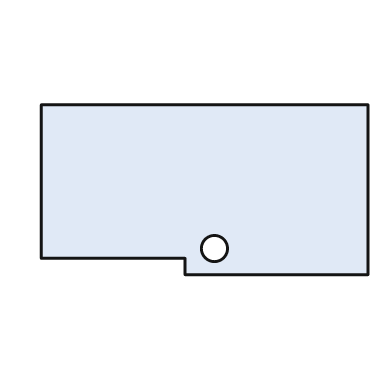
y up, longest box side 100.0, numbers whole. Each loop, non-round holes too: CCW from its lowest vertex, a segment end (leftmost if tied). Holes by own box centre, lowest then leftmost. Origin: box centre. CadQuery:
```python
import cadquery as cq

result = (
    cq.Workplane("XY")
    .moveTo(-6.0, -26.0)
    .lineTo(50.0, -26.0)
    .lineTo(50.0, 26.0)
    .lineTo(-50.0, 26.0)
    .lineTo(-50.0, -21.0)
    .lineTo(-6.0, -21.0)
    .close()
    .moveTo(3.0, -18.0)
    .circle(4.0)
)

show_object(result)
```